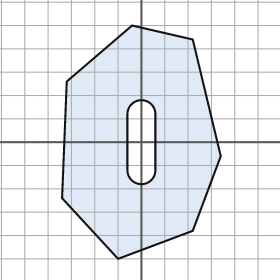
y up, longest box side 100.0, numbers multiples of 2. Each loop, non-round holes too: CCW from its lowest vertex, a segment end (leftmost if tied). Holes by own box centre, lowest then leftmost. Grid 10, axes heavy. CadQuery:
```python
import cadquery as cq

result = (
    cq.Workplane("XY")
    .moveTo(-10.0, -50.0)
    .lineTo(22.0, -38.0)
    .lineTo(34.0, -6.0)
    .lineTo(22.0, 44.0)
    .lineTo(-4.0, 50.0)
    .lineTo(-32.0, 26.0)
    .lineTo(-34.0, -24.0)
    .close()
    .moveTo(-6.0, -12.0)
    .threePointArc((0.0, -18.0), (6.0, -12.0))
    .lineTo(6.0, 12.0)
    .threePointArc((0.0, 18.0), (-6.0, 12.0))
    .close()
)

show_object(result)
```